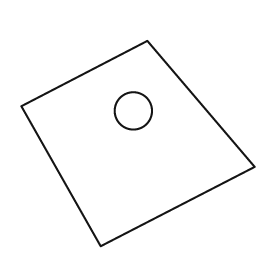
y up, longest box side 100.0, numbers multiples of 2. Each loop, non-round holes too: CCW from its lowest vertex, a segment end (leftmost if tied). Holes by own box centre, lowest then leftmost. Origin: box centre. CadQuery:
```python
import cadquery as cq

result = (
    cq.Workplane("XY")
    .moveTo(-16.0, -44.0)
    .lineTo(50.0, -10.0)
    .lineTo(4.0, 44.0)
    .lineTo(-50.0, 16.0)
    .close()
    .moveTo(-2.0, 14.0)
    .circle(8.0)
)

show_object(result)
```